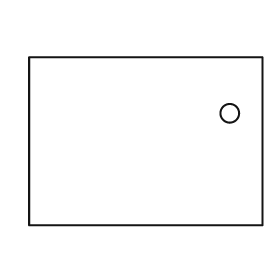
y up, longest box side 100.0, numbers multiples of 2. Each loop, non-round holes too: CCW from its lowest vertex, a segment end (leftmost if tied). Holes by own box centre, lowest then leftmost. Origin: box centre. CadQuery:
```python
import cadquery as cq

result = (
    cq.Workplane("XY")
    .moveTo(-50.0, -36.0)
    .lineTo(50.0, -36.0)
    .lineTo(50.0, 36.0)
    .lineTo(-50.0, 36.0)
    .close()
    .moveTo(36.0, 12.0)
    .circle(4.0)
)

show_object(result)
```